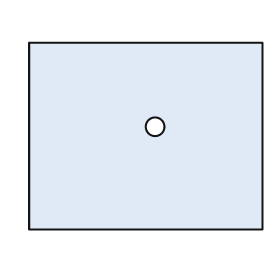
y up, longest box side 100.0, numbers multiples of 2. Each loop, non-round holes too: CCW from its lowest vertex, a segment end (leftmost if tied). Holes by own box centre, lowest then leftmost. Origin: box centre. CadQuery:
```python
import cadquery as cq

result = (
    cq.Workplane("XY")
    .moveTo(-50.0, -40.0)
    .lineTo(50.0, -40.0)
    .lineTo(50.0, 40.0)
    .lineTo(-50.0, 40.0)
    .close()
    .moveTo(4.0, 4.0)
    .circle(4.0)
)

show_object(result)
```